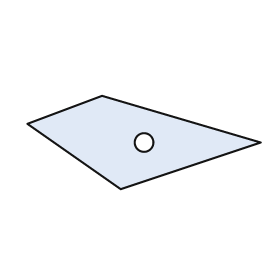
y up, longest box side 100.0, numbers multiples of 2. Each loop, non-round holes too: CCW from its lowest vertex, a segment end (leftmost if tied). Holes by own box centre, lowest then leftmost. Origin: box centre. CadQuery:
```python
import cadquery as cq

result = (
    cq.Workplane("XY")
    .moveTo(-10.0, -20.0)
    .lineTo(50.0, 0.0)
    .lineTo(-18.0, 20.0)
    .lineTo(-50.0, 8.0)
    .close()
    .moveTo(0.0, 0.0)
    .circle(4.0)
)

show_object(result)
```